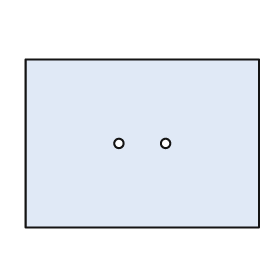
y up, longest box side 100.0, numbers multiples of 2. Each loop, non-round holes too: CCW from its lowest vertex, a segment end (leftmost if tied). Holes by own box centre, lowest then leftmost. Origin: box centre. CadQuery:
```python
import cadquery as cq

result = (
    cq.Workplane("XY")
    .moveTo(-50.0, -36.0)
    .lineTo(50.0, -36.0)
    .lineTo(50.0, 36.0)
    .lineTo(-50.0, 36.0)
    .close()
    .moveTo(-10.0, 0.0)
    .circle(2.0)
    .moveTo(10.0, 0.0)
    .circle(2.0)
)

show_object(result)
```